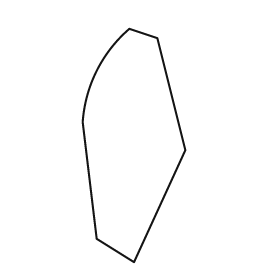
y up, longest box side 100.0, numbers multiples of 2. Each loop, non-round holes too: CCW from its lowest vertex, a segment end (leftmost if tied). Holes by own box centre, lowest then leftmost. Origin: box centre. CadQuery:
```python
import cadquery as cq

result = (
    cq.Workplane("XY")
    .moveTo(0.0, -50.0)
    .lineTo(22.0, -2.0)
    .lineTo(10.0, 46.0)
    .lineTo(-2.0, 50.0)
    .threePointArc((-16.0, 32.0), (-22.0, 10.0))
    .lineTo(-16.0, -40.0)
    .close()
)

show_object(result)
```